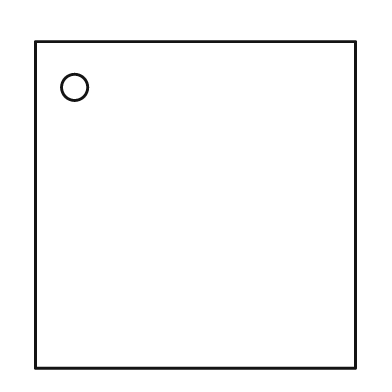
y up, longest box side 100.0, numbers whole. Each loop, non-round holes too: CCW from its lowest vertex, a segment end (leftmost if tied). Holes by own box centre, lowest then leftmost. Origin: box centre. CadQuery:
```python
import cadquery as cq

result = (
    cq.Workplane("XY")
    .moveTo(-49.0, -50.0)
    .lineTo(49.0, -50.0)
    .lineTo(49.0, 50.0)
    .lineTo(-49.0, 50.0)
    .close()
    .moveTo(-37.0, 36.0)
    .circle(4.0)
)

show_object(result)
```